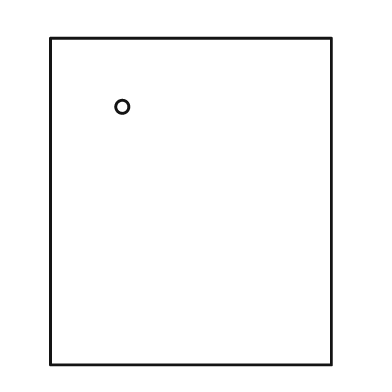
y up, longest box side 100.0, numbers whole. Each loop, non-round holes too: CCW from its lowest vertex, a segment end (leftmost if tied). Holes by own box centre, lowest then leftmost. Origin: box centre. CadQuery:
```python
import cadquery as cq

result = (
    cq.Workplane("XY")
    .moveTo(-43.0, -50.0)
    .lineTo(43.0, -50.0)
    .lineTo(43.0, 50.0)
    .lineTo(-43.0, 50.0)
    .close()
    .moveTo(-21.0, 29.0)
    .circle(2.0)
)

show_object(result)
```